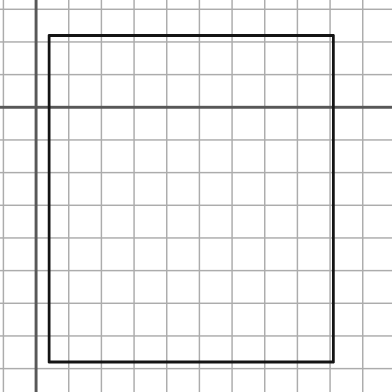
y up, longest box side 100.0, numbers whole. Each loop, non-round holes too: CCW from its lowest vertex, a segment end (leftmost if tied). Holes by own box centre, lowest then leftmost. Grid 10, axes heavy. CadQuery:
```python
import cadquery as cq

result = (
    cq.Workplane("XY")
    .moveTo(4.0, -78.0)
    .lineTo(91.0, -78.0)
    .lineTo(91.0, 22.0)
    .lineTo(4.0, 22.0)
    .close()
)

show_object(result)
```